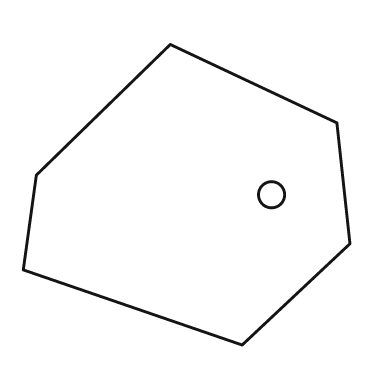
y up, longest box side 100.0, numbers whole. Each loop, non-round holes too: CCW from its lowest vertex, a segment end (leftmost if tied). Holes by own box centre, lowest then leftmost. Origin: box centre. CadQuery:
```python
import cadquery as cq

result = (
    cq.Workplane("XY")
    .moveTo(17.0, -46.0)
    .lineTo(50.0, -15.0)
    .lineTo(46.0, 22.0)
    .lineTo(-5.0, 46.0)
    .lineTo(-46.0, 6.0)
    .lineTo(-50.0, -23.0)
    .close()
    .moveTo(26.0, 0.0)
    .circle(4.0)
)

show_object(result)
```